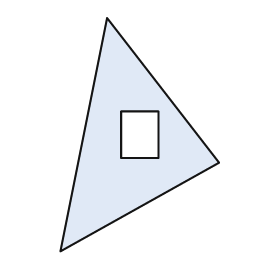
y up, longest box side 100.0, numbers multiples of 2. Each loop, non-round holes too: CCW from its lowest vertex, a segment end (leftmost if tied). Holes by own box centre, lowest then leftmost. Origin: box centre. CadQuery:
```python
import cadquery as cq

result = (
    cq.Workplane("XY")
    .moveTo(-34.0, -50.0)
    .lineTo(34.0, -12.0)
    .lineTo(-14.0, 50.0)
    .close()
    .moveTo(-8.0, -10.0)
    .lineTo(8.0, -10.0)
    .lineTo(8.0, 10.0)
    .lineTo(-8.0, 10.0)
    .close()
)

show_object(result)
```